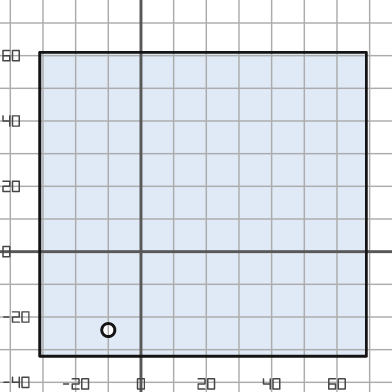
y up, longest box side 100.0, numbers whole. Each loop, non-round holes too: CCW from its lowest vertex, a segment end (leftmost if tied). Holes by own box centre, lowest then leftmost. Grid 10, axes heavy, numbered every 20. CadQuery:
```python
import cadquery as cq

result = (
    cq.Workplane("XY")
    .moveTo(-31.0, -32.0)
    .lineTo(69.0, -32.0)
    .lineTo(69.0, 61.0)
    .lineTo(-31.0, 61.0)
    .close()
    .moveTo(-10.0, -24.0)
    .circle(2.0)
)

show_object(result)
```